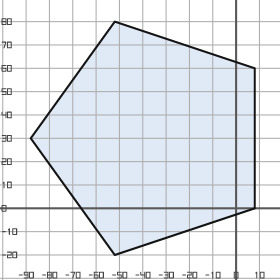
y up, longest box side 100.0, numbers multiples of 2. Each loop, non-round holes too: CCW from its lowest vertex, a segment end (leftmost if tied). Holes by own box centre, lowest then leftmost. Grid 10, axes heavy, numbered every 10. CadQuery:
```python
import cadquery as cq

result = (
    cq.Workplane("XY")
    .moveTo(-52.0, -20.0)
    .lineTo(8.0, 0.0)
    .lineTo(8.0, 60.0)
    .lineTo(-52.0, 80.0)
    .lineTo(-88.0, 30.0)
    .close()
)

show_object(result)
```